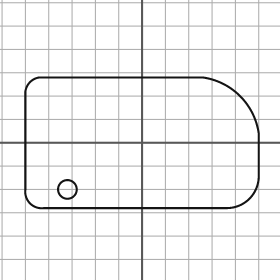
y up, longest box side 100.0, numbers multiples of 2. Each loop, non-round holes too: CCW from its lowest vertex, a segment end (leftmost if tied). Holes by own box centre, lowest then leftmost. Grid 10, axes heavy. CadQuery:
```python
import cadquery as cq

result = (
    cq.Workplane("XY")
    .moveTo(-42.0, -28.0)
    .lineTo(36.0, -28.0)
    .threePointArc((46.0, -24.0), (50.0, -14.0))
    .lineTo(50.0, 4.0)
    .threePointArc((42.0, 20.0), (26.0, 28.0))
    .lineTo(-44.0, 28.0)
    .threePointArc((-48.0, 26.0), (-50.0, 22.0))
    .lineTo(-50.0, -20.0)
    .threePointArc((-48.0, -26.0), (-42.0, -28.0))
    .close()
    .moveTo(-32.0, -20.0)
    .circle(4.0)
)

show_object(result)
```